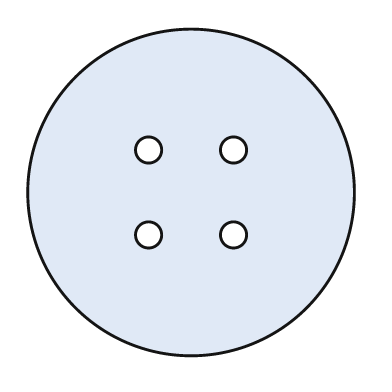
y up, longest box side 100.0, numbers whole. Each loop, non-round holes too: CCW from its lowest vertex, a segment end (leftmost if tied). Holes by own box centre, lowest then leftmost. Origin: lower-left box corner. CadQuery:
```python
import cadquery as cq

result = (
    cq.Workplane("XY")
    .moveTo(50.0, 50.0)
    .circle(50.0)
    .moveTo(37.0, 37.0)
    .circle(4.0)
    .moveTo(63.0, 37.0)
    .circle(4.0)
    .moveTo(37.0, 63.0)
    .circle(4.0)
    .moveTo(63.0, 63.0)
    .circle(4.0)
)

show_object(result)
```